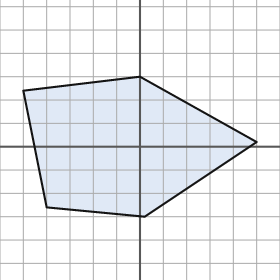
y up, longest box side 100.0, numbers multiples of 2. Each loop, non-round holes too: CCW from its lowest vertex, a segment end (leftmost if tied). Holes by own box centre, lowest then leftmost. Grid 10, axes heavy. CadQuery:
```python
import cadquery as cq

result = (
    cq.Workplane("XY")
    .moveTo(2.0, -30.0)
    .lineTo(50.0, 2.0)
    .lineTo(0.0, 30.0)
    .lineTo(-50.0, 24.0)
    .lineTo(-40.0, -26.0)
    .close()
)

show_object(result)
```